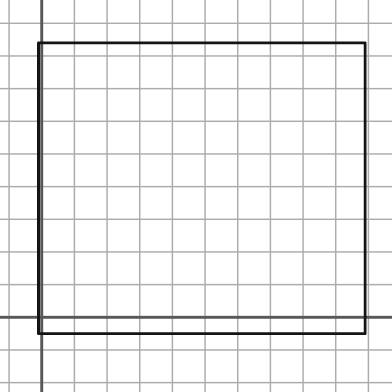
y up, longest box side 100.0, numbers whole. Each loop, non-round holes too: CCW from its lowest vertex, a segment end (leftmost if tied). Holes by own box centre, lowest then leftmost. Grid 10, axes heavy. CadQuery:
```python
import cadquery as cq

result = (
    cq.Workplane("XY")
    .moveTo(-1.0, -5.0)
    .lineTo(99.0, -5.0)
    .lineTo(99.0, 84.0)
    .lineTo(-1.0, 84.0)
    .close()
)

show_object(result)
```